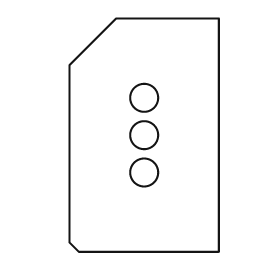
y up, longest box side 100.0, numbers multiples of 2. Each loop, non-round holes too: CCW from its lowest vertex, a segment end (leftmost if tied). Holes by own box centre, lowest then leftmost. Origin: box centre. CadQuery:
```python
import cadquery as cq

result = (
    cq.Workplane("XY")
    .moveTo(-28.0, -50.0)
    .lineTo(32.0, -50.0)
    .lineTo(32.0, 50.0)
    .lineTo(-12.0, 50.0)
    .lineTo(-32.0, 30.0)
    .lineTo(-32.0, -46.0)
    .close()
    .moveTo(0.0, -16.0)
    .circle(6.0)
    .moveTo(0.0, 0.0)
    .circle(6.0)
    .moveTo(0.0, 16.0)
    .circle(6.0)
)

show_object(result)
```